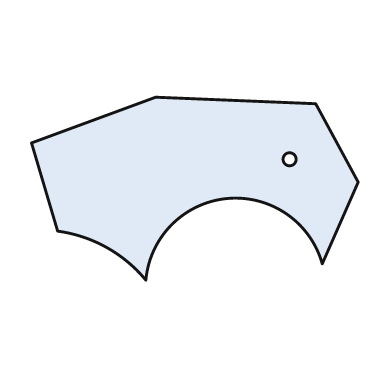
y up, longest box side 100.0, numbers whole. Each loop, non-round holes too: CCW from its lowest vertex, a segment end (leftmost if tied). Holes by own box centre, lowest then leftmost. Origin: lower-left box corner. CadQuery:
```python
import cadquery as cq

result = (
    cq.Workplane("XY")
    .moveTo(35.0, 0.0)
    .threePointArc((60.0, 25.0), (89.0, 5.0))
    .lineTo(100.0, 30.0)
    .lineTo(87.0, 54.0)
    .lineTo(38.0, 56.0)
    .lineTo(0.0, 42.0)
    .lineTo(8.0, 15.0)
    .threePointArc((23.0, 10.0), (35.0, 0.0))
    .close()
    .moveTo(79.0, 37.0)
    .circle(2.0)
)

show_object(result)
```